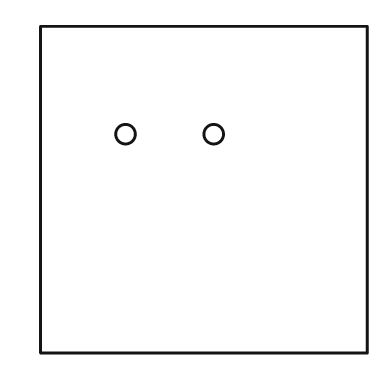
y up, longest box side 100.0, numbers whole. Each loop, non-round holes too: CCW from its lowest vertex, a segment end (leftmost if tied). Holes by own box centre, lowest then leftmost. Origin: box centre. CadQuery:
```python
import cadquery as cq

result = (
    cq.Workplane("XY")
    .moveTo(-50.0, -50.0)
    .lineTo(50.0, -50.0)
    .lineTo(50.0, 50.0)
    .lineTo(-50.0, 50.0)
    .close()
    .moveTo(-24.0, 17.0)
    .circle(3.0)
    .moveTo(3.0, 17.0)
    .circle(3.0)
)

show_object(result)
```